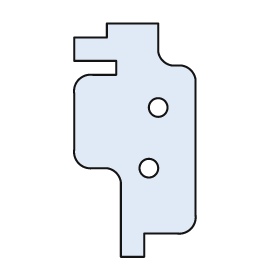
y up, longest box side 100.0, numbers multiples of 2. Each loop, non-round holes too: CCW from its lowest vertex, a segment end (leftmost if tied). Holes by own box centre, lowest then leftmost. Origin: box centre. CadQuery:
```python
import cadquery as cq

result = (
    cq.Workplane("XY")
    .moveTo(-6.0, -50.0)
    .lineTo(4.0, -50.0)
    .lineTo(4.0, -40.0)
    .lineTo(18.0, -40.0)
    .threePointArc((24.0, -38.0), (26.0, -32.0))
    .lineTo(26.0, 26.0)
    .threePointArc((24.0, 30.0), (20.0, 32.0))
    .lineTo(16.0, 32.0)
    .threePointArc((12.0, 34.0), (10.0, 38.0))
    .lineTo(10.0, 50.0)
    .lineTo(-12.0, 50.0)
    .lineTo(-12.0, 44.0)
    .lineTo(-26.0, 44.0)
    .lineTo(-26.0, 34.0)
    .lineTo(-8.0, 34.0)
    .lineTo(-8.0, 28.0)
    .lineTo(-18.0, 28.0)
    .threePointArc((-24.0, 26.0), (-26.0, 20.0))
    .lineTo(-26.0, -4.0)
    .threePointArc((-24.0, -10.0), (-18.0, -12.0))
    .lineTo(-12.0, -12.0)
    .threePointArc((-8.0, -14.0), (-6.0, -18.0))
    .close()
    .moveTo(6.0, -12.0)
    .circle(4.0)
    .moveTo(10.0, 14.0)
    .circle(4.0)
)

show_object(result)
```